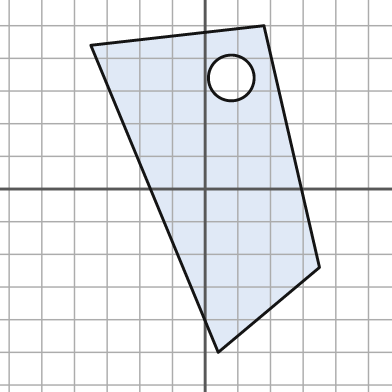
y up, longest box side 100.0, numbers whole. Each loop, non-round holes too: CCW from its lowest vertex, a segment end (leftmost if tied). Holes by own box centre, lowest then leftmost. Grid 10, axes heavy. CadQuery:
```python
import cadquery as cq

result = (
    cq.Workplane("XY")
    .moveTo(4.0, -50.0)
    .lineTo(35.0, -24.0)
    .lineTo(18.0, 50.0)
    .lineTo(-35.0, 44.0)
    .close()
    .moveTo(8.0, 34.0)
    .circle(7.0)
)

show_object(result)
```